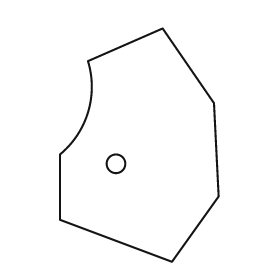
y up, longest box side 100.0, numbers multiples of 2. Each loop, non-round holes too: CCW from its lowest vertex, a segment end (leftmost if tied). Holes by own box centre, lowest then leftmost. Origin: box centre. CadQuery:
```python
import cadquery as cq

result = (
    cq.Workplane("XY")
    .moveTo(14.0, -50.0)
    .lineTo(34.0, -22.0)
    .lineTo(32.0, 18.0)
    .lineTo(10.0, 50.0)
    .lineTo(-22.0, 36.0)
    .threePointArc((-22.0, 14.0), (-34.0, -4.0))
    .lineTo(-34.0, -32.0)
    .close()
    .moveTo(-10.0, -8.0)
    .circle(4.0)
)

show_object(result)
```